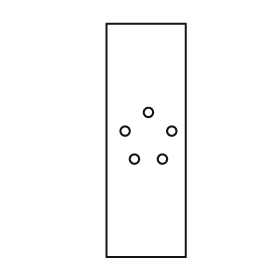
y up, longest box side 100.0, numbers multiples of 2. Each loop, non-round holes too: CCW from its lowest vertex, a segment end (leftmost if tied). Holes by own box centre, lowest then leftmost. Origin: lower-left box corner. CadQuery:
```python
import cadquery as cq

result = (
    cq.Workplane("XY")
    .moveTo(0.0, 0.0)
    .lineTo(34.0, 0.0)
    .lineTo(34.0, 100.0)
    .lineTo(0.0, 100.0)
    .close()
    .moveTo(12.0, 42.0)
    .circle(2.0)
    .moveTo(24.0, 42.0)
    .circle(2.0)
    .moveTo(8.0, 54.0)
    .circle(2.0)
    .moveTo(28.0, 54.0)
    .circle(2.0)
    .moveTo(18.0, 62.0)
    .circle(2.0)
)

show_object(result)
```